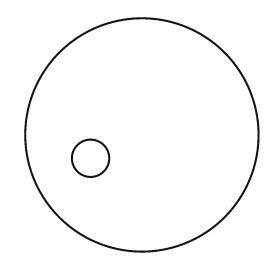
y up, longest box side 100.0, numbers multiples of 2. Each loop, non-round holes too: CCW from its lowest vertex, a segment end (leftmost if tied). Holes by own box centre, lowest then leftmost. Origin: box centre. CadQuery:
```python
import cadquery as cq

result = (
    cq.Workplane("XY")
    .moveTo(0.0, 0.0)
    .circle(50.0)
    .moveTo(-22.0, -10.0)
    .circle(8.0)
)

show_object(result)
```